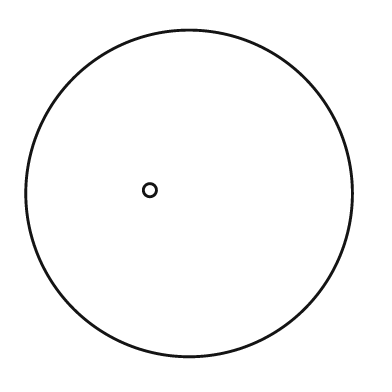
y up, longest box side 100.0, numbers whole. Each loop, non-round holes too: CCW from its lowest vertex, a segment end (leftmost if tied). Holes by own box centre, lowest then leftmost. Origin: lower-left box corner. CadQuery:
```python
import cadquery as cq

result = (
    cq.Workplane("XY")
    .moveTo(50.0, 50.0)
    .circle(50.0)
    .moveTo(38.0, 51.0)
    .circle(2.0)
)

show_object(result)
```